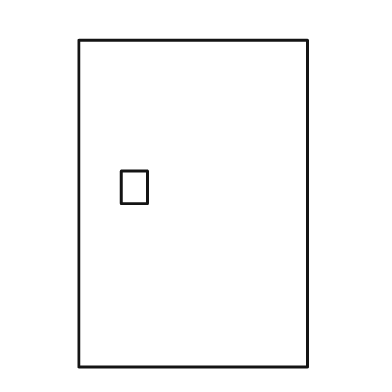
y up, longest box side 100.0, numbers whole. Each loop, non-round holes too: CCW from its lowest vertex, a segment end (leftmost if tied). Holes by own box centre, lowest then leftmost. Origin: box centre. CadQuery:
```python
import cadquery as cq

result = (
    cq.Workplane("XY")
    .moveTo(-35.0, -50.0)
    .lineTo(35.0, -50.0)
    .lineTo(35.0, 50.0)
    .lineTo(-35.0, 50.0)
    .close()
    .moveTo(-22.0, 0.0)
    .lineTo(-14.0, 0.0)
    .lineTo(-14.0, 10.0)
    .lineTo(-22.0, 10.0)
    .close()
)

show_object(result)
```